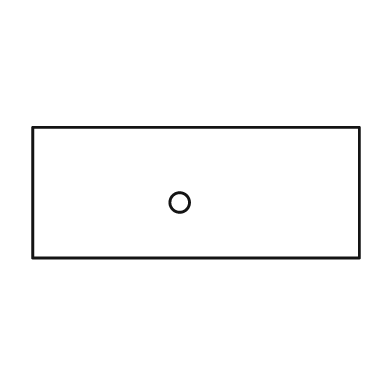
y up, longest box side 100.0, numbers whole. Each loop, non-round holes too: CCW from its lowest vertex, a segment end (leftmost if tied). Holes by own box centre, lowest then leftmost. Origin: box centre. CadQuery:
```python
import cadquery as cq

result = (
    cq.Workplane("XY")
    .moveTo(-50.0, -20.0)
    .lineTo(50.0, -20.0)
    .lineTo(50.0, 20.0)
    .lineTo(-50.0, 20.0)
    .close()
    .moveTo(-5.0, -3.0)
    .circle(3.0)
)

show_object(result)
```